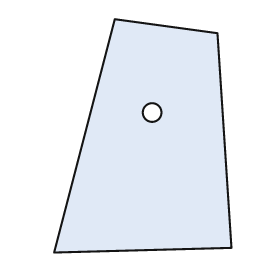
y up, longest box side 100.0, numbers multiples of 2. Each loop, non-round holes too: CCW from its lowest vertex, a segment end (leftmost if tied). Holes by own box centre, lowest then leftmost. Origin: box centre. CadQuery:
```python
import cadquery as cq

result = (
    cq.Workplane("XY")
    .moveTo(-38.0, -50.0)
    .lineTo(38.0, -48.0)
    .lineTo(32.0, 44.0)
    .lineTo(-12.0, 50.0)
    .close()
    .moveTo(4.0, 10.0)
    .circle(4.0)
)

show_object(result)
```